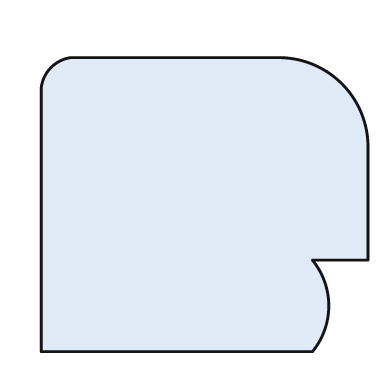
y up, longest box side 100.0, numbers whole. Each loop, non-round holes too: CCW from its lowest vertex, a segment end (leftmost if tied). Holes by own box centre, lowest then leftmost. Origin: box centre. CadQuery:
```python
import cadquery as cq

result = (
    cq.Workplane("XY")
    .moveTo(-50.0, -45.0)
    .lineTo(33.0, -45.0)
    .threePointArc((38.0, -31.0), (33.0, -17.0))
    .lineTo(50.0, -17.0)
    .lineTo(50.0, 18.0)
    .threePointArc((42.0, 37.0), (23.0, 45.0))
    .lineTo(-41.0, 45.0)
    .threePointArc((-47.0, 42.0), (-50.0, 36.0))
    .close()
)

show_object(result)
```